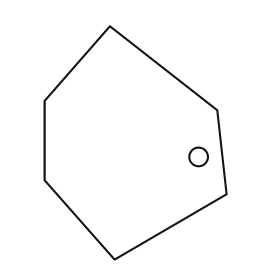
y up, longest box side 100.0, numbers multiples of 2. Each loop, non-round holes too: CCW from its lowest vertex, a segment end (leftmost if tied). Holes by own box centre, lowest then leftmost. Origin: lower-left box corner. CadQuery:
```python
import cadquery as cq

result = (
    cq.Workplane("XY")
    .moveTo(30.0, 0.0)
    .lineTo(78.0, 28.0)
    .lineTo(74.0, 64.0)
    .lineTo(28.0, 100.0)
    .lineTo(0.0, 68.0)
    .lineTo(0.0, 34.0)
    .close()
    .moveTo(66.0, 44.0)
    .circle(4.0)
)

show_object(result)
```